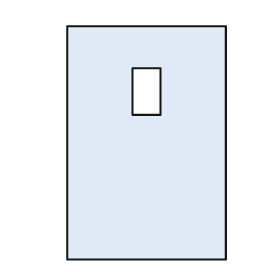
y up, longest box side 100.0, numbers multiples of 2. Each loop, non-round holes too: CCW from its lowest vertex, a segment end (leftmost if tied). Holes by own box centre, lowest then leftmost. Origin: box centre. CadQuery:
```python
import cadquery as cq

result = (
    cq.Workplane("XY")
    .moveTo(-34.0, -50.0)
    .lineTo(34.0, -50.0)
    .lineTo(34.0, 50.0)
    .lineTo(-34.0, 50.0)
    .close()
    .moveTo(-6.0, 12.0)
    .lineTo(6.0, 12.0)
    .lineTo(6.0, 32.0)
    .lineTo(-6.0, 32.0)
    .close()
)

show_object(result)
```